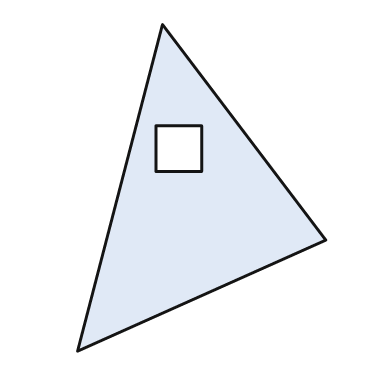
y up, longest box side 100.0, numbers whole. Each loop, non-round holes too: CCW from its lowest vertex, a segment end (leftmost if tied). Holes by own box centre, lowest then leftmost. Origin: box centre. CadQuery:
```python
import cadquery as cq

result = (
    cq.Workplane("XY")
    .moveTo(-38.0, -50.0)
    .lineTo(38.0, -16.0)
    .lineTo(-12.0, 50.0)
    .close()
    .moveTo(-14.0, 5.0)
    .lineTo(0.0, 5.0)
    .lineTo(0.0, 19.0)
    .lineTo(-14.0, 19.0)
    .close()
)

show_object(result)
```